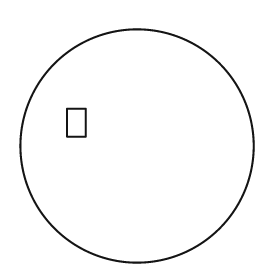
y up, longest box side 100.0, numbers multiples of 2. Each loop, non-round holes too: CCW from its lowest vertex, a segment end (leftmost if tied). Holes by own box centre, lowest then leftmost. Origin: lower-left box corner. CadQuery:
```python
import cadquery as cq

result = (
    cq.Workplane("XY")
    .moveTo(50.0, 50.0)
    .circle(50.0)
    .moveTo(20.0, 54.0)
    .lineTo(28.0, 54.0)
    .lineTo(28.0, 66.0)
    .lineTo(20.0, 66.0)
    .close()
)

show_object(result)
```